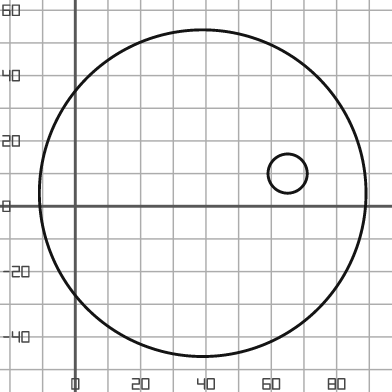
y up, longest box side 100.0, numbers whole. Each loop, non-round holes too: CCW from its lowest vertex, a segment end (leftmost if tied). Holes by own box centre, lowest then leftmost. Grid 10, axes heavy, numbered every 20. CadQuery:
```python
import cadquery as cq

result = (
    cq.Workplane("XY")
    .moveTo(39.0, 4.0)
    .circle(50.0)
    .moveTo(65.0, 10.0)
    .circle(6.0)
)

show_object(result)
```